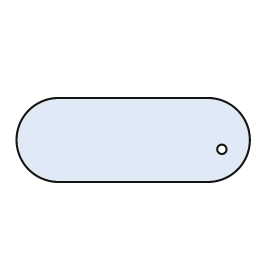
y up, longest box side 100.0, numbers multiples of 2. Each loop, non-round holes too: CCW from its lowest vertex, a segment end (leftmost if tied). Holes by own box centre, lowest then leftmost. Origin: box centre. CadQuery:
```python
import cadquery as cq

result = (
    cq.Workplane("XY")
    .moveTo(-32.0, -18.0)
    .lineTo(32.0, -18.0)
    .threePointArc((50.0, 0.0), (32.0, 18.0))
    .lineTo(-32.0, 18.0)
    .threePointArc((-50.0, 0.0), (-32.0, -18.0))
    .close()
    .moveTo(38.0, -4.0)
    .circle(2.0)
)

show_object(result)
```